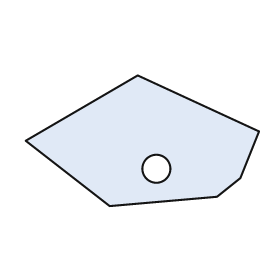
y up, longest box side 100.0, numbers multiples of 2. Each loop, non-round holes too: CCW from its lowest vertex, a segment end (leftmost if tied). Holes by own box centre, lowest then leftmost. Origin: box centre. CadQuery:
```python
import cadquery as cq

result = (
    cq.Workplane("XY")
    .moveTo(-14.0, -28.0)
    .lineTo(32.0, -24.0)
    .lineTo(42.0, -16.0)
    .lineTo(50.0, 4.0)
    .lineTo(-2.0, 28.0)
    .lineTo(-50.0, 0.0)
    .close()
    .moveTo(6.0, -12.0)
    .circle(6.0)
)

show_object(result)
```